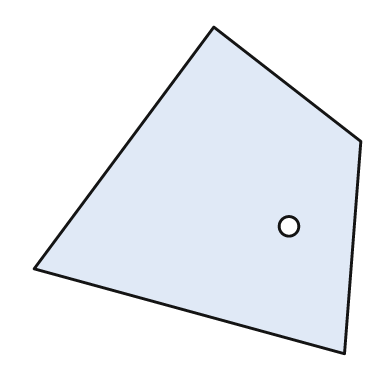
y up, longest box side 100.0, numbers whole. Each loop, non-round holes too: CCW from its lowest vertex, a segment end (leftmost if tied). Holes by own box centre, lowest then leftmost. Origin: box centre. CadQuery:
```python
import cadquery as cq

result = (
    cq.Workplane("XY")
    .moveTo(45.0, -50.0)
    .lineTo(50.0, 15.0)
    .lineTo(5.0, 50.0)
    .lineTo(-50.0, -24.0)
    .close()
    .moveTo(28.0, -11.0)
    .circle(3.0)
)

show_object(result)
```